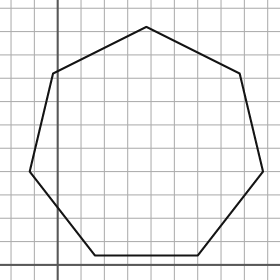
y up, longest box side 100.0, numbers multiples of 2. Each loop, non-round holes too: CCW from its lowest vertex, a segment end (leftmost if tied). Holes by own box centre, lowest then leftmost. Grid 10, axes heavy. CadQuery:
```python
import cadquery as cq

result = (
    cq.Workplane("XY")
    .moveTo(16.0, 4.0)
    .lineTo(60.0, 4.0)
    .lineTo(88.0, 40.0)
    .lineTo(78.0, 82.0)
    .lineTo(38.0, 102.0)
    .lineTo(-2.0, 82.0)
    .lineTo(-12.0, 40.0)
    .close()
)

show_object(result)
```